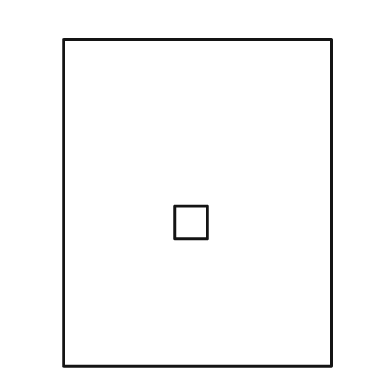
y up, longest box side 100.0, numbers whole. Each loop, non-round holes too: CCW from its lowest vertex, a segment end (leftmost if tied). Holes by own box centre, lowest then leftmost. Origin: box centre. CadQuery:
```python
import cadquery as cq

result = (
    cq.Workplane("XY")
    .moveTo(-41.0, -50.0)
    .lineTo(41.0, -50.0)
    .lineTo(41.0, 50.0)
    .lineTo(-41.0, 50.0)
    .close()
    .moveTo(-7.0, -11.0)
    .lineTo(3.0, -11.0)
    .lineTo(3.0, -1.0)
    .lineTo(-7.0, -1.0)
    .close()
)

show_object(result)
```